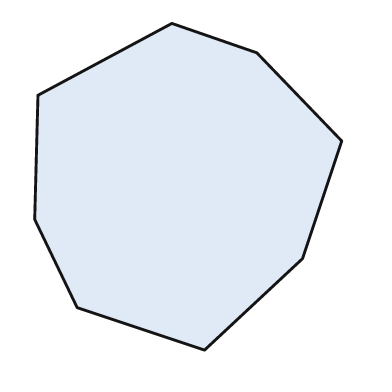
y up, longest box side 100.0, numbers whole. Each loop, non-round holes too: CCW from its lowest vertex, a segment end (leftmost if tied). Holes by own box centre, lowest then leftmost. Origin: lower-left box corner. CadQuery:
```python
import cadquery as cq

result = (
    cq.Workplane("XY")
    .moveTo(52.0, 0.0)
    .lineTo(82.0, 28.0)
    .lineTo(94.0, 64.0)
    .lineTo(68.0, 91.0)
    .lineTo(42.0, 100.0)
    .lineTo(1.0, 78.0)
    .lineTo(0.0, 40.0)
    .lineTo(13.0, 13.0)
    .close()
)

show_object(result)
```